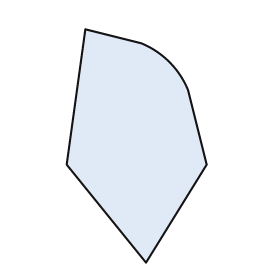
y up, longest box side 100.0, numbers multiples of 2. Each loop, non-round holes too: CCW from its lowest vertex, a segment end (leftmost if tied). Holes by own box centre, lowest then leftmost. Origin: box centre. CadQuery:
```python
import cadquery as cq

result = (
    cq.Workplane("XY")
    .moveTo(4.0, -50.0)
    .lineTo(30.0, -8.0)
    .lineTo(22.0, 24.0)
    .threePointArc((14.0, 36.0), (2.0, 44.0))
    .lineTo(-22.0, 50.0)
    .lineTo(-30.0, -8.0)
    .close()
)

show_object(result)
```